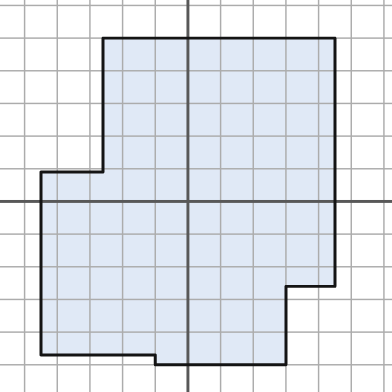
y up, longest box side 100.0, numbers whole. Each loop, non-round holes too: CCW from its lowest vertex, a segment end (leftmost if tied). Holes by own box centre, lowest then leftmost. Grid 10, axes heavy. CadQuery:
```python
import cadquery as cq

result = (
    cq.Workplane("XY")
    .moveTo(-10.0, -50.0)
    .lineTo(30.0, -50.0)
    .lineTo(30.0, -26.0)
    .lineTo(45.0, -26.0)
    .lineTo(45.0, 50.0)
    .lineTo(-26.0, 50.0)
    .lineTo(-26.0, 9.0)
    .lineTo(-45.0, 9.0)
    .lineTo(-45.0, -47.0)
    .lineTo(-10.0, -47.0)
    .close()
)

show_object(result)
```